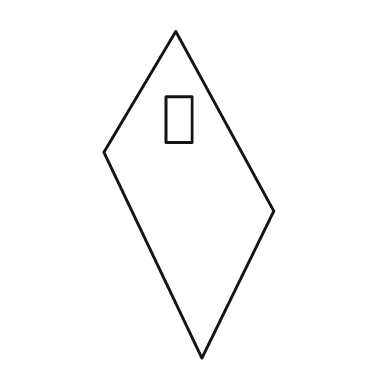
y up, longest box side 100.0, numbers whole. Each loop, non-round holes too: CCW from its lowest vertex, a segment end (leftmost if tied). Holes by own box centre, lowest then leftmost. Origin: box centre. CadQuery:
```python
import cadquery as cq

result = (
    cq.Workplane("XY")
    .moveTo(4.0, -50.0)
    .lineTo(26.0, -5.0)
    .lineTo(-4.0, 50.0)
    .lineTo(-26.0, 13.0)
    .close()
    .moveTo(-7.0, 16.0)
    .lineTo(1.0, 16.0)
    .lineTo(1.0, 30.0)
    .lineTo(-7.0, 30.0)
    .close()
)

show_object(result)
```